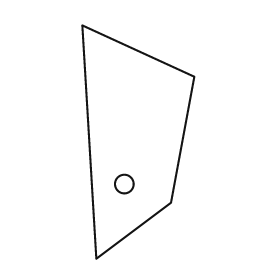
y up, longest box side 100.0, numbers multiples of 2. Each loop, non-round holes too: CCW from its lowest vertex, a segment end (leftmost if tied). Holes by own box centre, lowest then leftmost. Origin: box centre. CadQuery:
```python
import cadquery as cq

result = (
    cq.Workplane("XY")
    .moveTo(-18.0, -50.0)
    .lineTo(14.0, -26.0)
    .lineTo(24.0, 28.0)
    .lineTo(-24.0, 50.0)
    .close()
    .moveTo(-6.0, -18.0)
    .circle(4.0)
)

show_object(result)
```